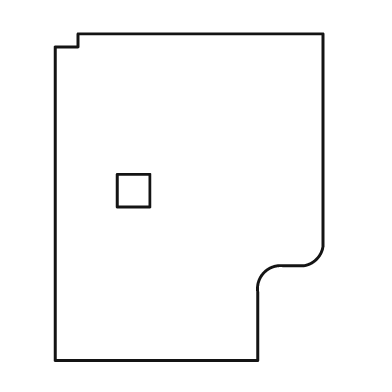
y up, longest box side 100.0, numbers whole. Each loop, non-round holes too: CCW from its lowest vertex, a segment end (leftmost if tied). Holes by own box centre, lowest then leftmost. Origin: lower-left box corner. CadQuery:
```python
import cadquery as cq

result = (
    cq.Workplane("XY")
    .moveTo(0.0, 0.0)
    .lineTo(62.0, 0.0)
    .lineTo(62.0, 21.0)
    .threePointArc((64.0, 27.0), (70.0, 29.0))
    .lineTo(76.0, 29.0)
    .threePointArc((80.0, 31.0), (82.0, 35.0))
    .lineTo(82.0, 100.0)
    .lineTo(7.0, 100.0)
    .lineTo(7.0, 96.0)
    .lineTo(0.0, 96.0)
    .close()
    .moveTo(19.0, 47.0)
    .lineTo(29.0, 47.0)
    .lineTo(29.0, 57.0)
    .lineTo(19.0, 57.0)
    .close()
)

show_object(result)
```